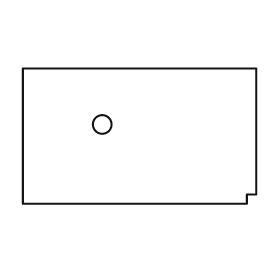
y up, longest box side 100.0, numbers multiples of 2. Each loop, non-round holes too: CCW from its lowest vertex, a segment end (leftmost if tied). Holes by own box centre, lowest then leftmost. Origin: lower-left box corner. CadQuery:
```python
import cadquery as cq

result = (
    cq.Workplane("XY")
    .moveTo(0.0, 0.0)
    .lineTo(96.0, 0.0)
    .lineTo(96.0, 4.0)
    .lineTo(100.0, 4.0)
    .lineTo(100.0, 58.0)
    .lineTo(0.0, 58.0)
    .close()
    .moveTo(34.0, 34.0)
    .circle(4.0)
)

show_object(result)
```